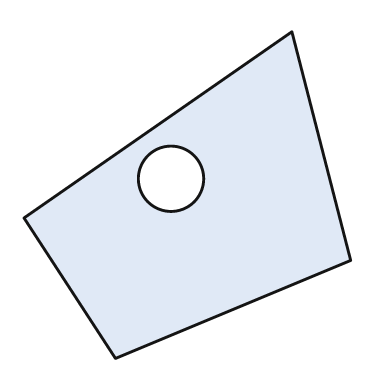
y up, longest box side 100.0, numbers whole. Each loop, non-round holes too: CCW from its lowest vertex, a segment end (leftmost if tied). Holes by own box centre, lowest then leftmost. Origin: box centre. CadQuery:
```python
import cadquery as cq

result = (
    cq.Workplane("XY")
    .moveTo(-22.0, -50.0)
    .lineTo(50.0, -20.0)
    .lineTo(32.0, 50.0)
    .lineTo(-50.0, -7.0)
    .close()
    .moveTo(-5.0, 5.0)
    .circle(10.0)
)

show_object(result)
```